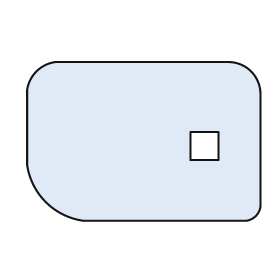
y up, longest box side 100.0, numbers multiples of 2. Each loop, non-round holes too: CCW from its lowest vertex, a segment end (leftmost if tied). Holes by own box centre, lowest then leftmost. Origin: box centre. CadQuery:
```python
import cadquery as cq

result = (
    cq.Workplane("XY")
    .moveTo(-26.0, -34.0)
    .lineTo(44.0, -34.0)
    .threePointArc((48.0, -32.0), (50.0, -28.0))
    .lineTo(50.0, 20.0)
    .threePointArc((46.0, 30.0), (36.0, 34.0))
    .lineTo(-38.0, 34.0)
    .threePointArc((-46.0, 30.0), (-50.0, 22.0))
    .lineTo(-50.0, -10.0)
    .threePointArc((-42.0, -26.0), (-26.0, -34.0))
    .close()
    .moveTo(20.0, -8.0)
    .lineTo(32.0, -8.0)
    .lineTo(32.0, 4.0)
    .lineTo(20.0, 4.0)
    .close()
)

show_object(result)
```